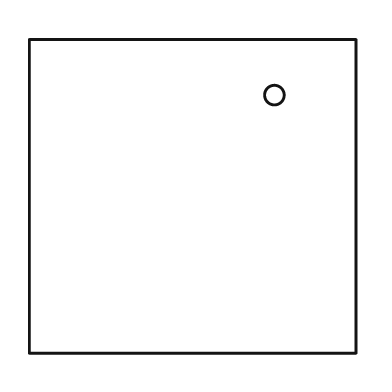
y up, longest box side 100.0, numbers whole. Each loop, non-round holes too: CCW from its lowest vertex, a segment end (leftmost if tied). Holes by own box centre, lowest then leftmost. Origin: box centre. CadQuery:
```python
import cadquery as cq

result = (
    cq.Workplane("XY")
    .moveTo(-50.0, -48.0)
    .lineTo(50.0, -48.0)
    .lineTo(50.0, 48.0)
    .lineTo(-50.0, 48.0)
    .close()
    .moveTo(25.0, 31.0)
    .circle(3.0)
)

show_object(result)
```